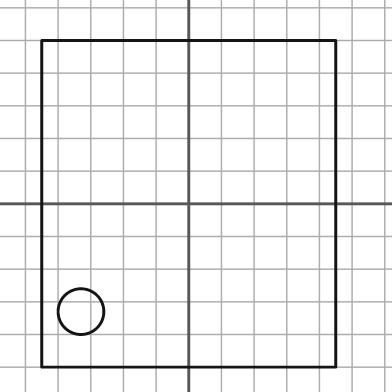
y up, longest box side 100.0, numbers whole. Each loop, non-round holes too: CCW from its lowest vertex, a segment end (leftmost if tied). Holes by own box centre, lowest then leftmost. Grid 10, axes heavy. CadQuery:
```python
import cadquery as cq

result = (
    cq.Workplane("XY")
    .moveTo(-45.0, -50.0)
    .lineTo(45.0, -50.0)
    .lineTo(45.0, 50.0)
    .lineTo(-45.0, 50.0)
    .close()
    .moveTo(-33.0, -33.0)
    .circle(7.0)
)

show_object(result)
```